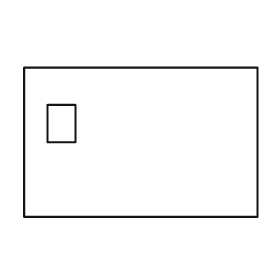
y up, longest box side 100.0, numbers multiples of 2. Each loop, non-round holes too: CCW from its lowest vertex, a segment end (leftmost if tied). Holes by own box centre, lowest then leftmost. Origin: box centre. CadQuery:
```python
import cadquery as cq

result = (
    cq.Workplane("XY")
    .moveTo(-50.0, -32.0)
    .lineTo(50.0, -32.0)
    .lineTo(50.0, 32.0)
    .lineTo(-50.0, 32.0)
    .close()
    .moveTo(-40.0, 0.0)
    .lineTo(-28.0, 0.0)
    .lineTo(-28.0, 16.0)
    .lineTo(-40.0, 16.0)
    .close()
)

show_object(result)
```